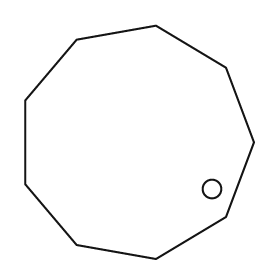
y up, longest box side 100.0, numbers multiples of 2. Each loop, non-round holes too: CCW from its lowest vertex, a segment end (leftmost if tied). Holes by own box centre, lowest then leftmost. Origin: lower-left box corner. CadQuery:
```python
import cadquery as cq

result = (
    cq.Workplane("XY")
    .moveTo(56.0, 0.0)
    .lineTo(86.0, 18.0)
    .lineTo(98.0, 50.0)
    .lineTo(86.0, 82.0)
    .lineTo(56.0, 100.0)
    .lineTo(22.0, 94.0)
    .lineTo(0.0, 68.0)
    .lineTo(0.0, 32.0)
    .lineTo(22.0, 6.0)
    .close()
    .moveTo(80.0, 30.0)
    .circle(4.0)
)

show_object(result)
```